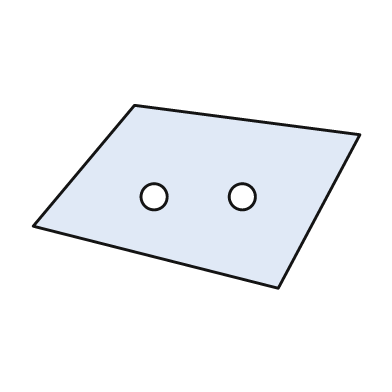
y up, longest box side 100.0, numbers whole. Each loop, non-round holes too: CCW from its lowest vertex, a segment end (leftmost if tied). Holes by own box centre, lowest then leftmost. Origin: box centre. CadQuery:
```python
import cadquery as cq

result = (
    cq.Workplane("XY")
    .moveTo(25.0, -28.0)
    .lineTo(50.0, 19.0)
    .lineTo(-19.0, 28.0)
    .lineTo(-50.0, -9.0)
    .close()
    .moveTo(-13.0, 0.0)
    .circle(4.0)
    .moveTo(14.0, 0.0)
    .circle(4.0)
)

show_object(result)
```